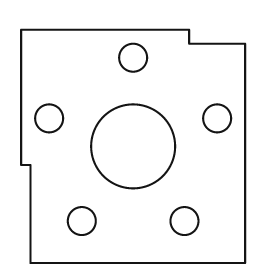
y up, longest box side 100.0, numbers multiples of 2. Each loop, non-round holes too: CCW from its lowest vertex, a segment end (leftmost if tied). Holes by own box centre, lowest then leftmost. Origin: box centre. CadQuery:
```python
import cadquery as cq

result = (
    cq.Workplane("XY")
    .moveTo(-44.0, -50.0)
    .lineTo(48.0, -50.0)
    .lineTo(48.0, 44.0)
    .lineTo(24.0, 44.0)
    .lineTo(24.0, 50.0)
    .lineTo(-48.0, 50.0)
    .lineTo(-48.0, -8.0)
    .lineTo(-44.0, -8.0)
    .close()
    .moveTo(-22.0, -32.0)
    .circle(6.0)
    .moveTo(22.0, -32.0)
    .circle(6.0)
    .moveTo(0.0, 0.0)
    .circle(18.0)
    .moveTo(-36.0, 12.0)
    .circle(6.0)
    .moveTo(36.0, 12.0)
    .circle(6.0)
    .moveTo(0.0, 38.0)
    .circle(6.0)
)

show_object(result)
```